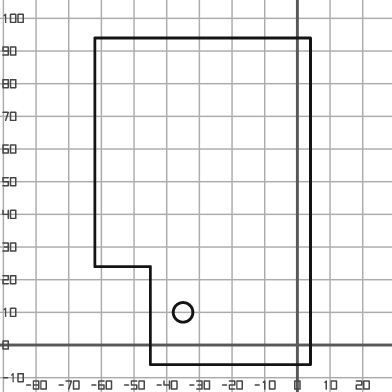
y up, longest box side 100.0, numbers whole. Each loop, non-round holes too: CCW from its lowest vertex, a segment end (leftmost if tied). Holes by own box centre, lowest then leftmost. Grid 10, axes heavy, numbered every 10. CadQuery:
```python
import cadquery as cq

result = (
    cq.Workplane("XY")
    .moveTo(-45.0, -6.0)
    .lineTo(4.0, -6.0)
    .lineTo(4.0, 94.0)
    .lineTo(-62.0, 94.0)
    .lineTo(-62.0, 24.0)
    .lineTo(-45.0, 24.0)
    .close()
    .moveTo(-35.0, 10.0)
    .circle(3.0)
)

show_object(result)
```